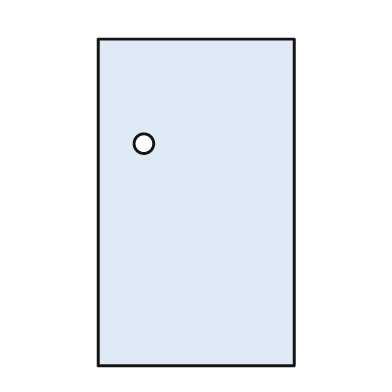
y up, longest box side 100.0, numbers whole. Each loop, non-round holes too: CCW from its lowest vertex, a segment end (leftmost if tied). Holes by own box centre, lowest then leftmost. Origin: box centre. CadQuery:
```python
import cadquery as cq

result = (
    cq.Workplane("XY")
    .moveTo(-30.0, -50.0)
    .lineTo(30.0, -50.0)
    .lineTo(30.0, 50.0)
    .lineTo(-30.0, 50.0)
    .close()
    .moveTo(-16.0, 18.0)
    .circle(3.0)
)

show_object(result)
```